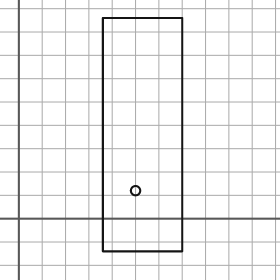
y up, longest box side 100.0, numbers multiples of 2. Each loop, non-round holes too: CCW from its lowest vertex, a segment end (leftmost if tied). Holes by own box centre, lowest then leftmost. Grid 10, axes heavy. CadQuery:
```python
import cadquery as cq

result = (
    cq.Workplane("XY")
    .moveTo(36.0, -14.0)
    .lineTo(70.0, -14.0)
    .lineTo(70.0, 86.0)
    .lineTo(36.0, 86.0)
    .close()
    .moveTo(50.0, 12.0)
    .circle(2.0)
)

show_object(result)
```